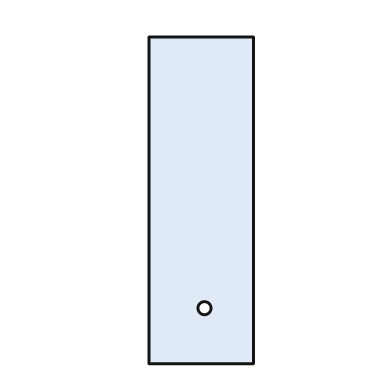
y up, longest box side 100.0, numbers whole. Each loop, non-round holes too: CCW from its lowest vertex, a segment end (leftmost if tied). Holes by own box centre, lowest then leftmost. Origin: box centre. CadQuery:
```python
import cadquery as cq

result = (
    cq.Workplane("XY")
    .moveTo(-16.0, -50.0)
    .lineTo(16.0, -50.0)
    .lineTo(16.0, 50.0)
    .lineTo(-16.0, 50.0)
    .close()
    .moveTo(1.0, -33.0)
    .circle(2.0)
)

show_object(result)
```